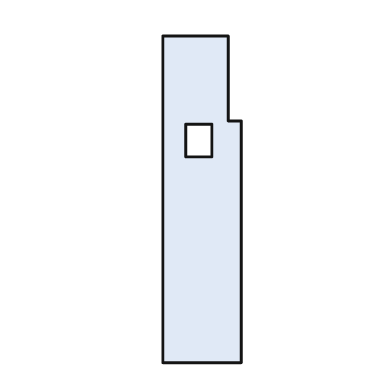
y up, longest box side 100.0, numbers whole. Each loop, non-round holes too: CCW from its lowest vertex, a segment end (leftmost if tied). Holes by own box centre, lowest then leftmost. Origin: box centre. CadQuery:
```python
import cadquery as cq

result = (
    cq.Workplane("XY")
    .moveTo(-12.0, -50.0)
    .lineTo(12.0, -50.0)
    .lineTo(12.0, 24.0)
    .lineTo(8.0, 24.0)
    .lineTo(8.0, 50.0)
    .lineTo(-12.0, 50.0)
    .close()
    .moveTo(-5.0, 13.0)
    .lineTo(3.0, 13.0)
    .lineTo(3.0, 23.0)
    .lineTo(-5.0, 23.0)
    .close()
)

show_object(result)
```